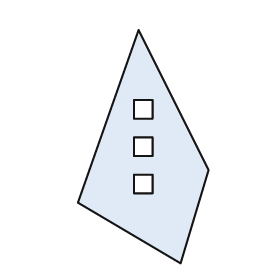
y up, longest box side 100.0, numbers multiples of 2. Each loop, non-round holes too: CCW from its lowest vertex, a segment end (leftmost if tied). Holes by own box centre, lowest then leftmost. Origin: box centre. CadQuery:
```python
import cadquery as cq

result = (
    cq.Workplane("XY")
    .moveTo(16.0, -50.0)
    .lineTo(28.0, -10.0)
    .lineTo(-2.0, 50.0)
    .lineTo(-28.0, -24.0)
    .close()
    .moveTo(-4.0, -20.0)
    .lineTo(4.0, -20.0)
    .lineTo(4.0, -12.0)
    .lineTo(-4.0, -12.0)
    .close()
    .moveTo(-4.0, -4.0)
    .lineTo(4.0, -4.0)
    .lineTo(4.0, 4.0)
    .lineTo(-4.0, 4.0)
    .close()
    .moveTo(-4.0, 12.0)
    .lineTo(4.0, 12.0)
    .lineTo(4.0, 20.0)
    .lineTo(-4.0, 20.0)
    .close()
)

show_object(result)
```